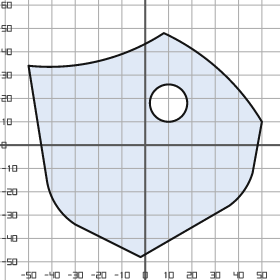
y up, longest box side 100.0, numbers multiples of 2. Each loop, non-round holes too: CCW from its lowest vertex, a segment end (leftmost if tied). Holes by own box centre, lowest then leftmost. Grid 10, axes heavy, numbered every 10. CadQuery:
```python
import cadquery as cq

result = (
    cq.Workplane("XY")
    .moveTo(-2.0, -48.0)
    .lineTo(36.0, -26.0)
    .threePointArc((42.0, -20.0), (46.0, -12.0))
    .lineTo(50.0, 10.0)
    .threePointArc((32.0, 32.0), (8.0, 48.0))
    .threePointArc((-20.0, 36.0), (-50.0, 34.0))
    .lineTo(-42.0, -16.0)
    .threePointArc((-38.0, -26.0), (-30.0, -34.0))
    .close()
    .moveTo(10.0, 18.0)
    .circle(8.0)
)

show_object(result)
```